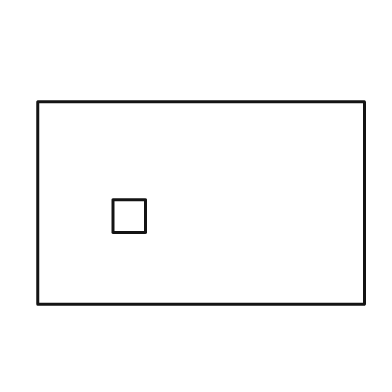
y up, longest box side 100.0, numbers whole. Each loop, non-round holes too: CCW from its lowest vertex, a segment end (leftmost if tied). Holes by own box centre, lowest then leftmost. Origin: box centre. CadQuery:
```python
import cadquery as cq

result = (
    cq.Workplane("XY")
    .moveTo(-50.0, -31.0)
    .lineTo(50.0, -31.0)
    .lineTo(50.0, 31.0)
    .lineTo(-50.0, 31.0)
    .close()
    .moveTo(-27.0, -9.0)
    .lineTo(-17.0, -9.0)
    .lineTo(-17.0, 1.0)
    .lineTo(-27.0, 1.0)
    .close()
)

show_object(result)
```